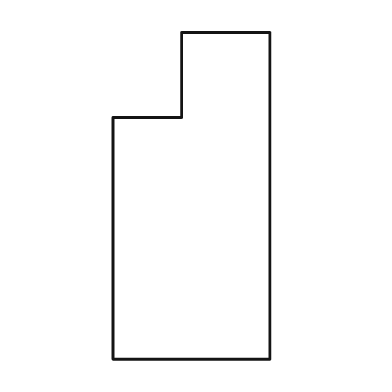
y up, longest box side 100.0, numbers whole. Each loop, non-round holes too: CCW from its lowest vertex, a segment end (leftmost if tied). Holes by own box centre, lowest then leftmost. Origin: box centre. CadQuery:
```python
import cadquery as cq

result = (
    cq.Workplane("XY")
    .moveTo(-24.0, -50.0)
    .lineTo(24.0, -50.0)
    .lineTo(24.0, 50.0)
    .lineTo(-3.0, 50.0)
    .lineTo(-3.0, 24.0)
    .lineTo(-24.0, 24.0)
    .close()
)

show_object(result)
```